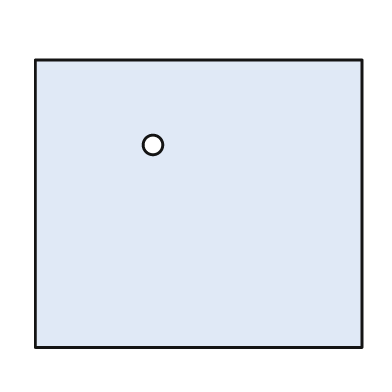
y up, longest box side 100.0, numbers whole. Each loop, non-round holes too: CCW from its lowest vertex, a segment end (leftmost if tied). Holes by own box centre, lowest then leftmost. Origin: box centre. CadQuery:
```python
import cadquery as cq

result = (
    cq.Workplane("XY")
    .moveTo(-50.0, -44.0)
    .lineTo(50.0, -44.0)
    .lineTo(50.0, 44.0)
    .lineTo(-50.0, 44.0)
    .close()
    .moveTo(-14.0, 18.0)
    .circle(3.0)
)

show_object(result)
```